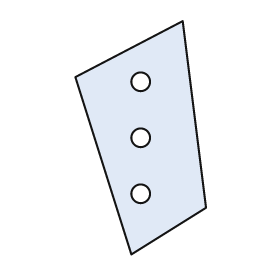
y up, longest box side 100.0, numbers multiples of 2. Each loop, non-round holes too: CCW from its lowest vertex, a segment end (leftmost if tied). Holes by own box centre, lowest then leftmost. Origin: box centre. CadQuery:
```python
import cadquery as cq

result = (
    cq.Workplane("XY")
    .moveTo(-4.0, -50.0)
    .lineTo(28.0, -30.0)
    .lineTo(18.0, 50.0)
    .lineTo(-28.0, 26.0)
    .close()
    .moveTo(0.0, -24.0)
    .circle(4.0)
    .moveTo(0.0, 0.0)
    .circle(4.0)
    .moveTo(0.0, 24.0)
    .circle(4.0)
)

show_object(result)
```